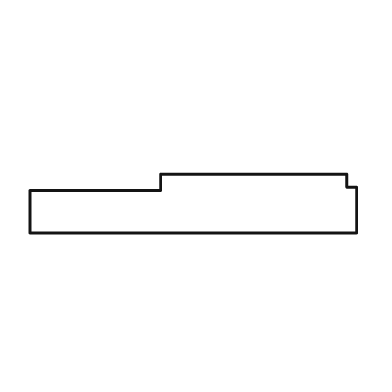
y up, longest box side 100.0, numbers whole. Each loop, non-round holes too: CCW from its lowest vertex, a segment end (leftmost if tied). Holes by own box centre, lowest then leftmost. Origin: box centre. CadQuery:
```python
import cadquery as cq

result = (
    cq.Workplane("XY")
    .moveTo(-50.0, -9.0)
    .lineTo(50.0, -9.0)
    .lineTo(50.0, 5.0)
    .lineTo(47.0, 5.0)
    .lineTo(47.0, 9.0)
    .lineTo(-10.0, 9.0)
    .lineTo(-10.0, 4.0)
    .lineTo(-50.0, 4.0)
    .close()
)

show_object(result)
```